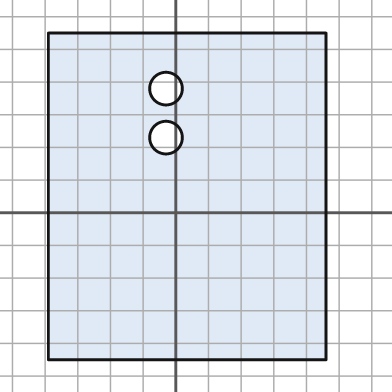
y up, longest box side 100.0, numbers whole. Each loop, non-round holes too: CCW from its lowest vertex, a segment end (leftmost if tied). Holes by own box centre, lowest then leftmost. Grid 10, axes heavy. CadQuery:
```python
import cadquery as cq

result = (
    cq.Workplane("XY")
    .moveTo(-39.0, -45.0)
    .lineTo(46.0, -45.0)
    .lineTo(46.0, 55.0)
    .lineTo(-39.0, 55.0)
    .close()
    .moveTo(-3.0, 23.0)
    .circle(5.0)
    .moveTo(-3.0, 38.0)
    .circle(5.0)
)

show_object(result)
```